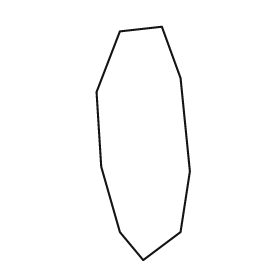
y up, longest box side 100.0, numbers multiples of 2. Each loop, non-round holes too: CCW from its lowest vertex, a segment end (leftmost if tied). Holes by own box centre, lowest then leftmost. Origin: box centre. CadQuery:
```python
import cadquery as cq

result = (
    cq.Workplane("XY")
    .moveTo(0.0, -50.0)
    .lineTo(16.0, -38.0)
    .lineTo(20.0, -12.0)
    .lineTo(16.0, 28.0)
    .lineTo(8.0, 50.0)
    .lineTo(-10.0, 48.0)
    .lineTo(-20.0, 22.0)
    .lineTo(-18.0, -10.0)
    .lineTo(-10.0, -38.0)
    .close()
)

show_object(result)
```